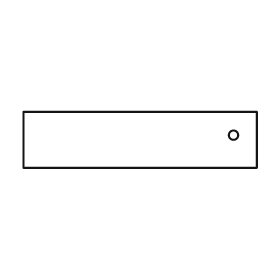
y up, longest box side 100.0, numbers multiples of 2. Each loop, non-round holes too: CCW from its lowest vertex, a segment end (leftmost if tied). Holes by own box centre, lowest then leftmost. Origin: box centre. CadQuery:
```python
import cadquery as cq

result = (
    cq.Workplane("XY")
    .moveTo(-50.0, -12.0)
    .lineTo(50.0, -12.0)
    .lineTo(50.0, 12.0)
    .lineTo(-50.0, 12.0)
    .close()
    .moveTo(40.0, 2.0)
    .circle(2.0)
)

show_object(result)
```